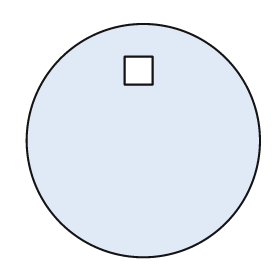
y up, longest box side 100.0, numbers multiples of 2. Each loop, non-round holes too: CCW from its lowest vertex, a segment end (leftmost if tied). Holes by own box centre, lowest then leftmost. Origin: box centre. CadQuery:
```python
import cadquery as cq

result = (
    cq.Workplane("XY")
    .moveTo(0.0, 0.0)
    .circle(50.0)
    .moveTo(-8.0, 24.0)
    .lineTo(4.0, 24.0)
    .lineTo(4.0, 36.0)
    .lineTo(-8.0, 36.0)
    .close()
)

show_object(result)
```